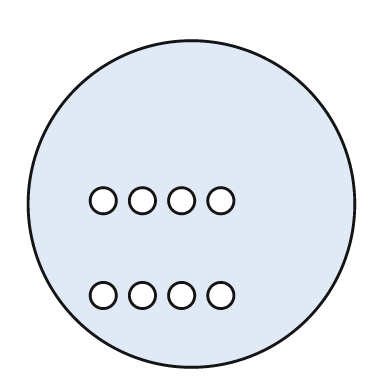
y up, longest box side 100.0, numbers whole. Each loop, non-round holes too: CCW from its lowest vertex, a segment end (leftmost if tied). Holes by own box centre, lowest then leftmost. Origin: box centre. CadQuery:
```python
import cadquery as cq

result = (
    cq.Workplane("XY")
    .moveTo(0.0, 0.0)
    .circle(50.0)
    .moveTo(-27.0, -28.0)
    .circle(4.0)
    .moveTo(-15.0, -28.0)
    .circle(4.0)
    .moveTo(-3.0, -28.0)
    .circle(4.0)
    .moveTo(9.0, -28.0)
    .circle(4.0)
    .moveTo(-27.0, 1.0)
    .circle(4.0)
    .moveTo(-15.0, 1.0)
    .circle(4.0)
    .moveTo(-3.0, 1.0)
    .circle(4.0)
    .moveTo(9.0, 1.0)
    .circle(4.0)
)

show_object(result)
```